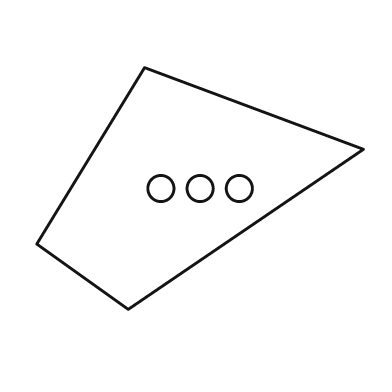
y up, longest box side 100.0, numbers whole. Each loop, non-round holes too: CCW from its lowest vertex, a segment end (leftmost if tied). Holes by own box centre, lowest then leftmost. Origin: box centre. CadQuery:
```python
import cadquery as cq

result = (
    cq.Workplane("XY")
    .moveTo(-22.0, -37.0)
    .lineTo(50.0, 12.0)
    .lineTo(-17.0, 37.0)
    .lineTo(-50.0, -17.0)
    .close()
    .moveTo(-12.0, 0.0)
    .circle(4.0)
    .moveTo(0.0, 0.0)
    .circle(4.0)
    .moveTo(12.0, 0.0)
    .circle(4.0)
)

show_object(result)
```